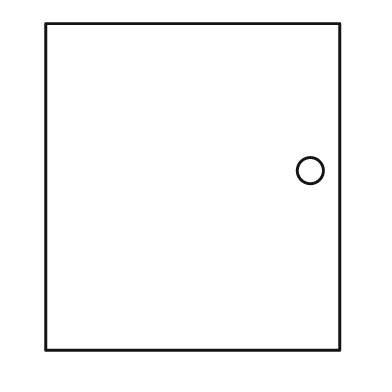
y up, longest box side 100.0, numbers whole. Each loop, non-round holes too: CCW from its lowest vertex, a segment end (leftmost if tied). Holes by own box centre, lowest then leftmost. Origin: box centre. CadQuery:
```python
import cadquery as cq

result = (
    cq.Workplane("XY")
    .moveTo(-45.0, -50.0)
    .lineTo(45.0, -50.0)
    .lineTo(45.0, 50.0)
    .lineTo(-45.0, 50.0)
    .close()
    .moveTo(36.0, 5.0)
    .circle(4.0)
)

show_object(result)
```